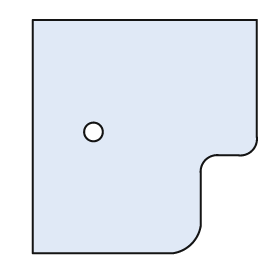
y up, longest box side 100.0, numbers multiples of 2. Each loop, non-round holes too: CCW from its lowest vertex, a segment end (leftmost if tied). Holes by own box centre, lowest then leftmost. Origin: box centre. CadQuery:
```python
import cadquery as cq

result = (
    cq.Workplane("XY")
    .moveTo(-48.0, -50.0)
    .lineTo(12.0, -50.0)
    .threePointArc((20.0, -46.0), (24.0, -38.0))
    .lineTo(24.0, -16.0)
    .threePointArc((26.0, -10.0), (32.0, -8.0))
    .lineTo(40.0, -8.0)
    .threePointArc((46.0, -6.0), (48.0, 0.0))
    .lineTo(48.0, 50.0)
    .lineTo(-48.0, 50.0)
    .close()
    .moveTo(-22.0, 2.0)
    .circle(4.0)
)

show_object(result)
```